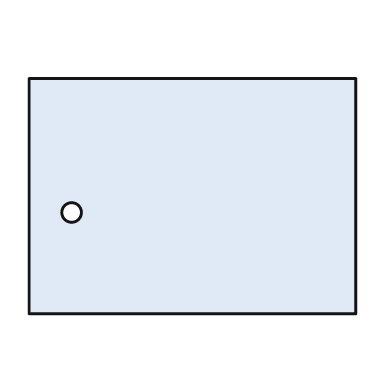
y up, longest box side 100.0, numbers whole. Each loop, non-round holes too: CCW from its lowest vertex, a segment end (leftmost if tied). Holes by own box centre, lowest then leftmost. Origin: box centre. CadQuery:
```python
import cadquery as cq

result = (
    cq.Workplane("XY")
    .moveTo(-50.0, -36.0)
    .lineTo(50.0, -36.0)
    .lineTo(50.0, 36.0)
    .lineTo(-50.0, 36.0)
    .close()
    .moveTo(-37.0, -5.0)
    .circle(3.0)
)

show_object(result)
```